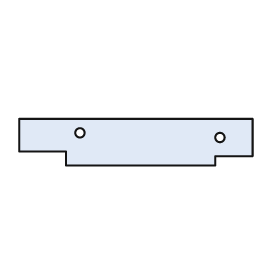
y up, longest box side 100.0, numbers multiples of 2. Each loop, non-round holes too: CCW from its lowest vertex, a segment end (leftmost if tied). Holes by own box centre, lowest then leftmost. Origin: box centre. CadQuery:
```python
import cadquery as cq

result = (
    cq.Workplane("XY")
    .moveTo(-30.0, -10.0)
    .lineTo(34.0, -10.0)
    .lineTo(34.0, -6.0)
    .lineTo(50.0, -6.0)
    .lineTo(50.0, 10.0)
    .lineTo(-50.0, 10.0)
    .lineTo(-50.0, -4.0)
    .lineTo(-30.0, -4.0)
    .close()
    .moveTo(36.0, 2.0)
    .circle(2.0)
    .moveTo(-24.0, 4.0)
    .circle(2.0)
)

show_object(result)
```